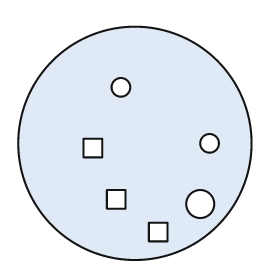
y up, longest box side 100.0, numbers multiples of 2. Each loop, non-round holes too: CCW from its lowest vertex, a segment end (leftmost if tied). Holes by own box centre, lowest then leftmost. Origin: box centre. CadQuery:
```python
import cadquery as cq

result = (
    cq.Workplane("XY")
    .moveTo(0.0, 0.0)
    .circle(50.0)
    .moveTo(6.0, -42.0)
    .lineTo(14.0, -42.0)
    .lineTo(14.0, -34.0)
    .lineTo(6.0, -34.0)
    .close()
    .moveTo(28.0, -26.0)
    .circle(6.0)
    .moveTo(-12.0, -28.0)
    .lineTo(-4.0, -28.0)
    .lineTo(-4.0, -20.0)
    .lineTo(-12.0, -20.0)
    .close()
    .moveTo(-22.0, -6.0)
    .lineTo(-14.0, -6.0)
    .lineTo(-14.0, 2.0)
    .lineTo(-22.0, 2.0)
    .close()
    .moveTo(32.0, 0.0)
    .circle(4.0)
    .moveTo(-6.0, 24.0)
    .circle(4.0)
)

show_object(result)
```